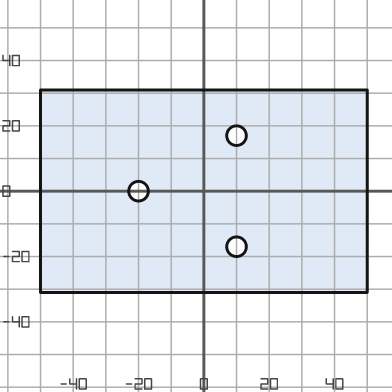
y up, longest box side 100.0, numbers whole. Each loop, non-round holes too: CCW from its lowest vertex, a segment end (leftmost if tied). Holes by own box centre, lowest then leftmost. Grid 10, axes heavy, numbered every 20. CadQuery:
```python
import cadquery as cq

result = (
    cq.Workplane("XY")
    .moveTo(-50.0, -31.0)
    .lineTo(50.0, -31.0)
    .lineTo(50.0, 31.0)
    .lineTo(-50.0, 31.0)
    .close()
    .moveTo(10.0, -17.0)
    .circle(3.0)
    .moveTo(-20.0, 0.0)
    .circle(3.0)
    .moveTo(10.0, 17.0)
    .circle(3.0)
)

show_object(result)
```